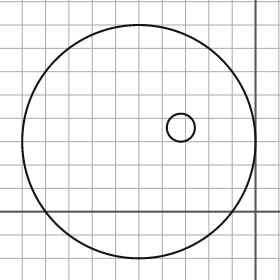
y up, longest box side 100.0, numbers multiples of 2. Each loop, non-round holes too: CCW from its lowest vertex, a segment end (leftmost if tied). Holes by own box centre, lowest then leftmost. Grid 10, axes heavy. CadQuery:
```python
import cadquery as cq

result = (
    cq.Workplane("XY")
    .moveTo(-50.0, 30.0)
    .circle(50.0)
    .moveTo(-32.0, 36.0)
    .circle(6.0)
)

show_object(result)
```